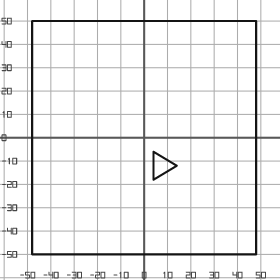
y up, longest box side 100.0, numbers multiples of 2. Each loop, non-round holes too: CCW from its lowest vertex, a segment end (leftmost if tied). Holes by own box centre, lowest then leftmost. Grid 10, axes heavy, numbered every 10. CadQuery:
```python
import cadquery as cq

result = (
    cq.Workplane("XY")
    .moveTo(-48.0, -50.0)
    .lineTo(48.0, -50.0)
    .lineTo(48.0, 50.0)
    .lineTo(-48.0, 50.0)
    .close()
    .moveTo(4.0, -18.0)
    .lineTo(14.0, -12.0)
    .lineTo(4.0, -6.0)
    .close()
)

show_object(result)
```